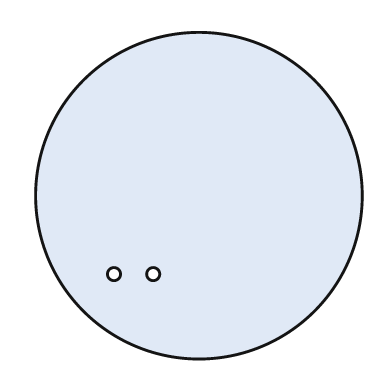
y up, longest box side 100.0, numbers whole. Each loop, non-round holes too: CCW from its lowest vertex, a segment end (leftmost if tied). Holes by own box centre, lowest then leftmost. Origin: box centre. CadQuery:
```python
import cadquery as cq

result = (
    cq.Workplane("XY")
    .moveTo(0.0, 0.0)
    .circle(50.0)
    .moveTo(-26.0, -24.0)
    .circle(2.0)
    .moveTo(-14.0, -24.0)
    .circle(2.0)
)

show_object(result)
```